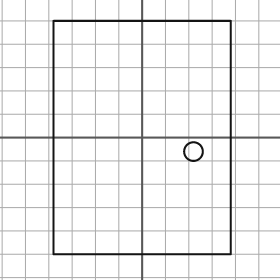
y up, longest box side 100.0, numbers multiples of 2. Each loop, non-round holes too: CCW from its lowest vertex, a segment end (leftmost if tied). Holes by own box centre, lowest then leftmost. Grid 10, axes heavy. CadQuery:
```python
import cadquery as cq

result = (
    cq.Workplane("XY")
    .moveTo(-38.0, -50.0)
    .lineTo(38.0, -50.0)
    .lineTo(38.0, 50.0)
    .lineTo(-38.0, 50.0)
    .close()
    .moveTo(22.0, -6.0)
    .circle(4.0)
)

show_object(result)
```